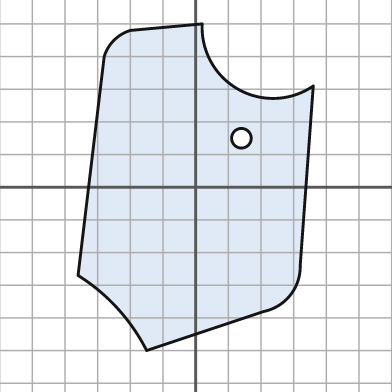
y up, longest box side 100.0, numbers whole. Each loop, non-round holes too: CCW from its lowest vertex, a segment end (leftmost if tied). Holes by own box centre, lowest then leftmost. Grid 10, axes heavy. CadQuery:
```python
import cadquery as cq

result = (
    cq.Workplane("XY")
    .moveTo(-15.0, -50.0)
    .lineTo(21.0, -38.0)
    .threePointArc((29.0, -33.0), (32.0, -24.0))
    .lineTo(36.0, 31.0)
    .threePointArc((13.0, 30.0), (2.0, 50.0))
    .lineTo(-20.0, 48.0)
    .threePointArc((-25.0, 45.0), (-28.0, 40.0))
    .lineTo(-36.0, -27.0)
    .threePointArc((-24.0, -37.0), (-15.0, -50.0))
    .close()
    .moveTo(14.0, 15.0)
    .circle(3.0)
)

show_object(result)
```